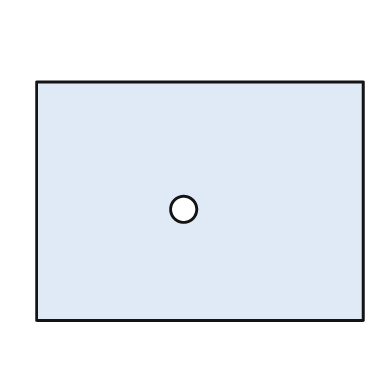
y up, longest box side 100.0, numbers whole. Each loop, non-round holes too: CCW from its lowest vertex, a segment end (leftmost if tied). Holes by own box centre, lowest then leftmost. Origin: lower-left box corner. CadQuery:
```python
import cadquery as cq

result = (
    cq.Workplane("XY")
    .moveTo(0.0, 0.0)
    .lineTo(100.0, 0.0)
    .lineTo(100.0, 73.0)
    .lineTo(0.0, 73.0)
    .close()
    .moveTo(45.0, 34.0)
    .circle(4.0)
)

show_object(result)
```